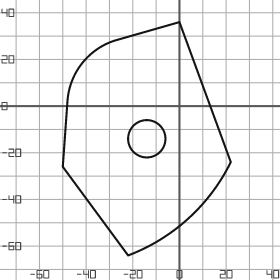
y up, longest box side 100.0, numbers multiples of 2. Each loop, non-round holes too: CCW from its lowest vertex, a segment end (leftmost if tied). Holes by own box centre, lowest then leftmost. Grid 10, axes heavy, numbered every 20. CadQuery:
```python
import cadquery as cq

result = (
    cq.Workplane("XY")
    .moveTo(-22.0, -64.0)
    .threePointArc((4.0, -48.0), (22.0, -24.0))
    .lineTo(0.0, 36.0)
    .lineTo(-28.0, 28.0)
    .threePointArc((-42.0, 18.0), (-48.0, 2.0))
    .lineTo(-50.0, -26.0)
    .close()
    .moveTo(-14.0, -14.0)
    .circle(8.0)
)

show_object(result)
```